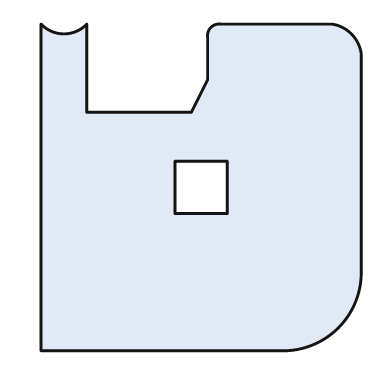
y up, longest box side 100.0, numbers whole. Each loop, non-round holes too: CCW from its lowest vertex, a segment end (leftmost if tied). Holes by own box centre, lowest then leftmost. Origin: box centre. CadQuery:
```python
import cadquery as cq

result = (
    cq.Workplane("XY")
    .moveTo(-49.0, -50.0)
    .lineTo(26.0, -50.0)
    .threePointArc((42.0, -43.0), (49.0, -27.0))
    .lineTo(49.0, 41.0)
    .threePointArc((46.0, 47.0), (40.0, 50.0))
    .lineTo(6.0, 50.0)
    .threePointArc((3.0, 49.0), (2.0, 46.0))
    .lineTo(2.0, 33.0)
    .lineTo(-3.0, 23.0)
    .lineTo(-35.0, 23.0)
    .lineTo(-35.0, 50.0)
    .threePointArc((-42.0, 47.0), (-49.0, 50.0))
    .close()
    .moveTo(-8.0, -8.0)
    .lineTo(8.0, -8.0)
    .lineTo(8.0, 8.0)
    .lineTo(-8.0, 8.0)
    .close()
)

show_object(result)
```